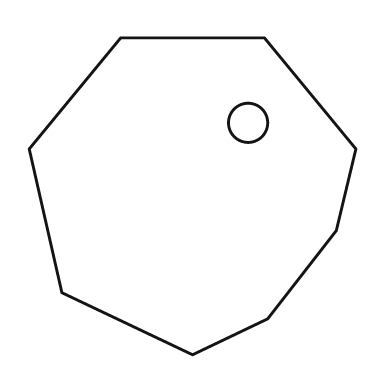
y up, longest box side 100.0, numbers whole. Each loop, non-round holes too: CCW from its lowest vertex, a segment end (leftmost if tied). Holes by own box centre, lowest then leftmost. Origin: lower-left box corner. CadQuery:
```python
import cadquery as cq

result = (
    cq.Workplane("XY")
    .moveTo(50.0, 0.0)
    .lineTo(73.0, 11.0)
    .lineTo(94.0, 38.0)
    .lineTo(100.0, 63.0)
    .lineTo(72.0, 97.0)
    .lineTo(28.0, 97.0)
    .lineTo(0.0, 63.0)
    .lineTo(10.0, 19.0)
    .close()
    .moveTo(67.0, 71.0)
    .circle(6.0)
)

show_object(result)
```